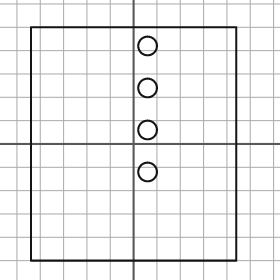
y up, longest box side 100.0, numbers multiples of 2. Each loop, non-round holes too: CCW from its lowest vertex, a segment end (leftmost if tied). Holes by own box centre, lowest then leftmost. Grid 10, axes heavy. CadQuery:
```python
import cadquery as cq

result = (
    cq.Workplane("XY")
    .moveTo(-44.0, -50.0)
    .lineTo(44.0, -50.0)
    .lineTo(44.0, 50.0)
    .lineTo(-44.0, 50.0)
    .close()
    .moveTo(6.0, -12.0)
    .circle(4.0)
    .moveTo(6.0, 6.0)
    .circle(4.0)
    .moveTo(6.0, 24.0)
    .circle(4.0)
    .moveTo(6.0, 42.0)
    .circle(4.0)
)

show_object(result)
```